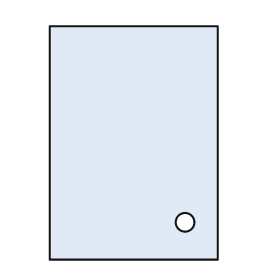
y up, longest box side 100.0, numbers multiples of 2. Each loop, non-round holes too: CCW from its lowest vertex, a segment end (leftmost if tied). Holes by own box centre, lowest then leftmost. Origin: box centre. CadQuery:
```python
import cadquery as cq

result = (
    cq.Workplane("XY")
    .moveTo(-36.0, -50.0)
    .lineTo(36.0, -50.0)
    .lineTo(36.0, 50.0)
    .lineTo(-36.0, 50.0)
    .close()
    .moveTo(22.0, -34.0)
    .circle(4.0)
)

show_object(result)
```